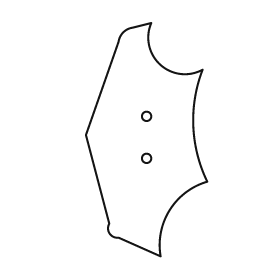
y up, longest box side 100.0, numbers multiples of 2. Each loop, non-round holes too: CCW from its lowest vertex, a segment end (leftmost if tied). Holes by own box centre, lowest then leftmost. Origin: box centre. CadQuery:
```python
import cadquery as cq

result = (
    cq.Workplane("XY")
    .moveTo(6.0, -50.0)
    .threePointArc((10.0, -30.0), (26.0, -18.0))
    .threePointArc((20.0, 6.0), (24.0, 30.0))
    .threePointArc((6.0, 32.0), (2.0, 50.0))
    .lineTo(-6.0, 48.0)
    .threePointArc((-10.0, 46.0), (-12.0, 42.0))
    .lineTo(-26.0, 2.0)
    .lineTo(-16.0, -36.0)
    .threePointArc((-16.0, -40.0), (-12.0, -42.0))
    .close()
    .moveTo(0.0, -8.0)
    .circle(2.0)
    .moveTo(0.0, 10.0)
    .circle(2.0)
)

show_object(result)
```